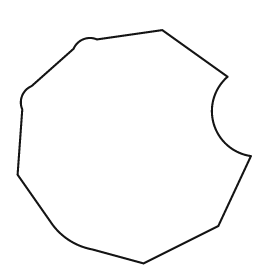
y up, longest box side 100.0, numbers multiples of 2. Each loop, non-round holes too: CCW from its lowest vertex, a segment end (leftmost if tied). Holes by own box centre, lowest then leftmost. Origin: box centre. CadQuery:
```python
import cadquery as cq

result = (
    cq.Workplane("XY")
    .moveTo(4.0, -50.0)
    .lineTo(36.0, -34.0)
    .lineTo(50.0, -4.0)
    .threePointArc((34.0, 10.0), (40.0, 30.0))
    .lineTo(12.0, 50.0)
    .lineTo(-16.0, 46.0)
    .threePointArc((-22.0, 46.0), (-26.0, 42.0))
    .lineTo(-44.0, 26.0)
    .threePointArc((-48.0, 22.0), (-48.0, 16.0))
    .lineTo(-50.0, -12.0)
    .lineTo(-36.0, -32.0)
    .threePointArc((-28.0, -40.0), (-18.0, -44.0))
    .close()
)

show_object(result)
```